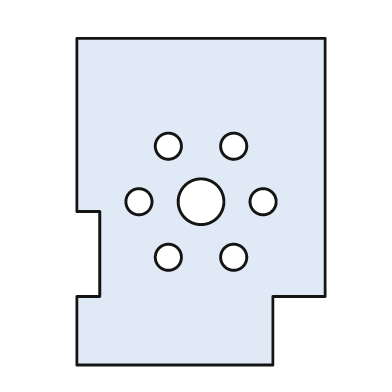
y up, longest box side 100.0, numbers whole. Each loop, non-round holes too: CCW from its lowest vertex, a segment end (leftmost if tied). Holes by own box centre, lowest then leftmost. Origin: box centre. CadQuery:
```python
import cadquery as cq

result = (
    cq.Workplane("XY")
    .moveTo(-38.0, -50.0)
    .lineTo(22.0, -50.0)
    .lineTo(22.0, -29.0)
    .lineTo(38.0, -29.0)
    .lineTo(38.0, 50.0)
    .lineTo(-38.0, 50.0)
    .lineTo(-38.0, -3.0)
    .lineTo(-31.0, -3.0)
    .lineTo(-31.0, -29.0)
    .lineTo(-38.0, -29.0)
    .close()
    .moveTo(-10.0, -17.0)
    .circle(4.0)
    .moveTo(10.0, -17.0)
    .circle(4.0)
    .moveTo(-19.0, 0.0)
    .circle(4.0)
    .moveTo(0.0, 0.0)
    .circle(7.0)
    .moveTo(19.0, 0.0)
    .circle(4.0)
    .moveTo(-10.0, 17.0)
    .circle(4.0)
    .moveTo(10.0, 17.0)
    .circle(4.0)
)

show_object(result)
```